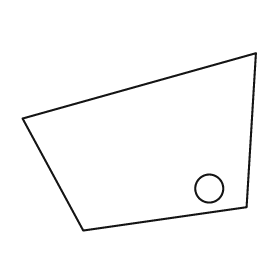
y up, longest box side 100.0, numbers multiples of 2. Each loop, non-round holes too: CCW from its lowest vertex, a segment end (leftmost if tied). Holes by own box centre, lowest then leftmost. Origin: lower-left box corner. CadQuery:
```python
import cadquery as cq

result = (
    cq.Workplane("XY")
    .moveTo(26.0, 0.0)
    .lineTo(96.0, 10.0)
    .lineTo(100.0, 76.0)
    .lineTo(0.0, 48.0)
    .close()
    .moveTo(80.0, 18.0)
    .circle(6.0)
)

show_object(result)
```